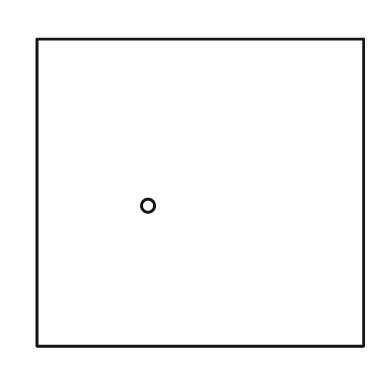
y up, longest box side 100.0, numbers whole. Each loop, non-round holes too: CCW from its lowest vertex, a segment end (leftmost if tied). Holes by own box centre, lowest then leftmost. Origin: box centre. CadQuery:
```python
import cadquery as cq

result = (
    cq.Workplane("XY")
    .moveTo(-50.0, -47.0)
    .lineTo(50.0, -47.0)
    .lineTo(50.0, 47.0)
    .lineTo(-50.0, 47.0)
    .close()
    .moveTo(-16.0, -4.0)
    .circle(2.0)
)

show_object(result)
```